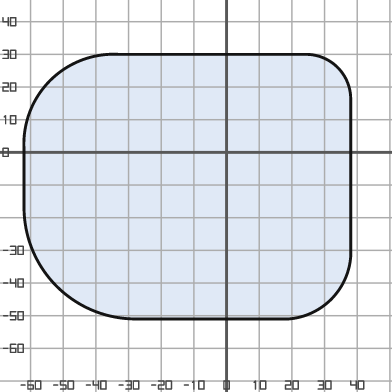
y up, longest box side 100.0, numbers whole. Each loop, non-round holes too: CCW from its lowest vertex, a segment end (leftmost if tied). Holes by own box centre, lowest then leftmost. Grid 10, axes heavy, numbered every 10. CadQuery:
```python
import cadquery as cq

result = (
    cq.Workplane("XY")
    .moveTo(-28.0, -51.0)
    .lineTo(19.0, -51.0)
    .threePointArc((32.0, -45.0), (38.0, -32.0))
    .lineTo(38.0, 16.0)
    .threePointArc((34.0, 26.0), (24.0, 30.0))
    .lineTo(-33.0, 30.0)
    .threePointArc((-54.0, 22.0), (-62.0, 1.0))
    .lineTo(-62.0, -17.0)
    .threePointArc((-52.0, -41.0), (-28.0, -51.0))
    .close()
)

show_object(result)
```